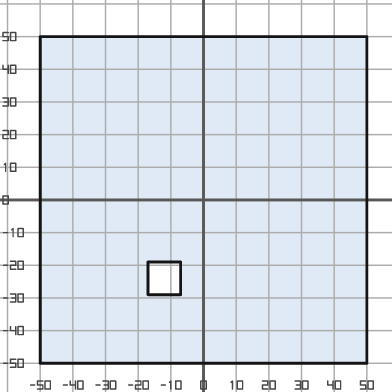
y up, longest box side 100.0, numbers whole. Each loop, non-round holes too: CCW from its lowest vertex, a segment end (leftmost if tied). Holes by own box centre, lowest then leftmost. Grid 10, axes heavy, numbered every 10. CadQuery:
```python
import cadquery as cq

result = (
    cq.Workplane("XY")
    .moveTo(-50.0, -50.0)
    .lineTo(50.0, -50.0)
    .lineTo(50.0, 50.0)
    .lineTo(-50.0, 50.0)
    .close()
    .moveTo(-17.0, -29.0)
    .lineTo(-7.0, -29.0)
    .lineTo(-7.0, -19.0)
    .lineTo(-17.0, -19.0)
    .close()
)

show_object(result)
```